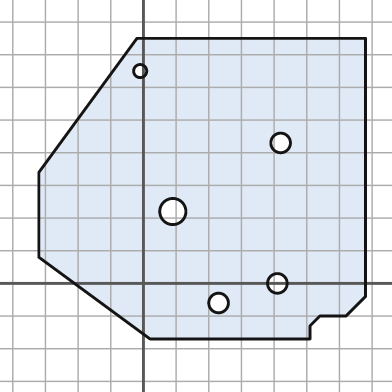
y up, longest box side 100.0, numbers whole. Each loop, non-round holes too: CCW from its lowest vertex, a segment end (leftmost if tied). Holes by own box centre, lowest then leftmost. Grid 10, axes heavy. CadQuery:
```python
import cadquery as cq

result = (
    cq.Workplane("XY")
    .moveTo(2.0, -17.0)
    .lineTo(51.0, -17.0)
    .lineTo(51.0, -13.0)
    .lineTo(54.0, -10.0)
    .lineTo(62.0, -10.0)
    .lineTo(68.0, -4.0)
    .lineTo(68.0, 75.0)
    .lineTo(-2.0, 75.0)
    .lineTo(-32.0, 34.0)
    .lineTo(-32.0, 8.0)
    .close()
    .moveTo(23.0, -6.0)
    .circle(3.0)
    .moveTo(41.0, 0.0)
    .circle(3.0)
    .moveTo(9.0, 22.0)
    .circle(4.0)
    .moveTo(42.0, 43.0)
    .circle(3.0)
    .moveTo(-1.0, 65.0)
    .circle(2.0)
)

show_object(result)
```